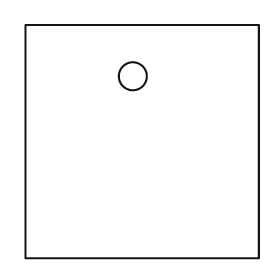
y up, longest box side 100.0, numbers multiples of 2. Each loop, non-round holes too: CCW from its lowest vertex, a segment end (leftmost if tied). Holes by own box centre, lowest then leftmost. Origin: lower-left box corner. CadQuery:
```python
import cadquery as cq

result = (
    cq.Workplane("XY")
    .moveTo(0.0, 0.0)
    .lineTo(100.0, 0.0)
    .lineTo(100.0, 100.0)
    .lineTo(0.0, 100.0)
    .close()
    .moveTo(46.0, 78.0)
    .circle(6.0)
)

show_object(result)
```